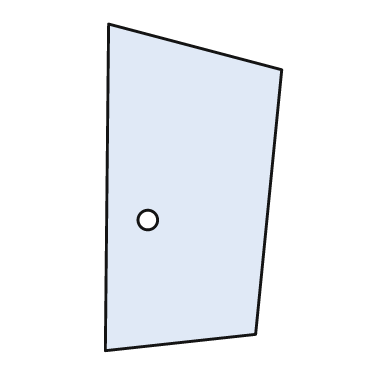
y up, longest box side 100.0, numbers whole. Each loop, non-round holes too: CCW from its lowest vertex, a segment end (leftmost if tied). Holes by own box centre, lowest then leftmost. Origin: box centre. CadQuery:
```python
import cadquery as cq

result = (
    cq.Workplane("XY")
    .moveTo(-27.0, -50.0)
    .lineTo(19.0, -45.0)
    .lineTo(27.0, 36.0)
    .lineTo(-26.0, 50.0)
    .close()
    .moveTo(-14.0, -10.0)
    .circle(3.0)
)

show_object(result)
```